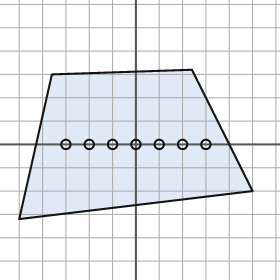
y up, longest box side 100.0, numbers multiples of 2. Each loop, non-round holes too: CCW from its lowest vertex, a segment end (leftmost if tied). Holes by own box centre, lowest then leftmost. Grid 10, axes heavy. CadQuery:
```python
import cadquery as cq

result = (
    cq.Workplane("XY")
    .moveTo(-50.0, -32.0)
    .lineTo(50.0, -20.0)
    .lineTo(24.0, 32.0)
    .lineTo(-36.0, 30.0)
    .close()
    .moveTo(-30.0, 0.0)
    .circle(2.0)
    .moveTo(-20.0, 0.0)
    .circle(2.0)
    .moveTo(-10.0, 0.0)
    .circle(2.0)
    .moveTo(0.0, 0.0)
    .circle(2.0)
    .moveTo(10.0, 0.0)
    .circle(2.0)
    .moveTo(20.0, 0.0)
    .circle(2.0)
    .moveTo(30.0, 0.0)
    .circle(2.0)
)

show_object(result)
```